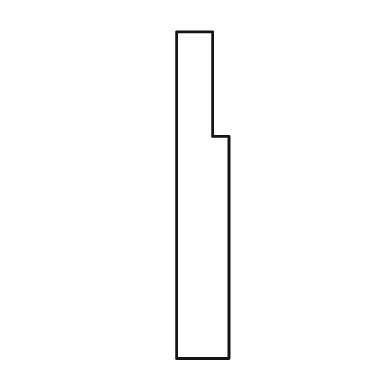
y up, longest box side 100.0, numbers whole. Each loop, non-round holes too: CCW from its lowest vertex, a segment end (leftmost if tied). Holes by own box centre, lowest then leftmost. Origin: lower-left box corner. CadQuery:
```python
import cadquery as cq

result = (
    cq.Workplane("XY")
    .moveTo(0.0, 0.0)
    .lineTo(16.0, 0.0)
    .lineTo(16.0, 68.0)
    .lineTo(11.0, 68.0)
    .lineTo(11.0, 100.0)
    .lineTo(0.0, 100.0)
    .close()
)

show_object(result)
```